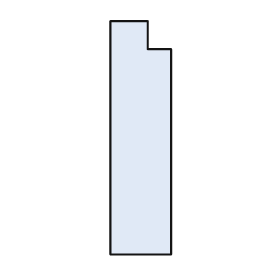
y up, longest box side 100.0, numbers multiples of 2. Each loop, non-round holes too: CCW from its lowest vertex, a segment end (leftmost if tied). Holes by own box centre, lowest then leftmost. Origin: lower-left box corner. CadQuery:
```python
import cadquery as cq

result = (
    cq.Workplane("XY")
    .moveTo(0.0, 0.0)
    .lineTo(26.0, 0.0)
    .lineTo(26.0, 88.0)
    .lineTo(16.0, 88.0)
    .lineTo(16.0, 100.0)
    .lineTo(0.0, 100.0)
    .close()
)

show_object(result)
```